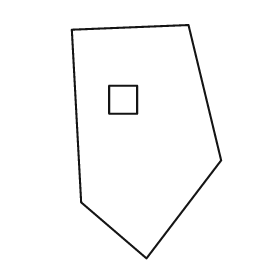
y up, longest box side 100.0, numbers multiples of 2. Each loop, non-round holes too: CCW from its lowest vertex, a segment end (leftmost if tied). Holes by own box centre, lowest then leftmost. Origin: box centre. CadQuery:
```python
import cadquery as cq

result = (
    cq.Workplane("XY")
    .moveTo(0.0, -50.0)
    .lineTo(32.0, -8.0)
    .lineTo(18.0, 50.0)
    .lineTo(-32.0, 48.0)
    .lineTo(-28.0, -26.0)
    .close()
    .moveTo(-16.0, 12.0)
    .lineTo(-4.0, 12.0)
    .lineTo(-4.0, 24.0)
    .lineTo(-16.0, 24.0)
    .close()
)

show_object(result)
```